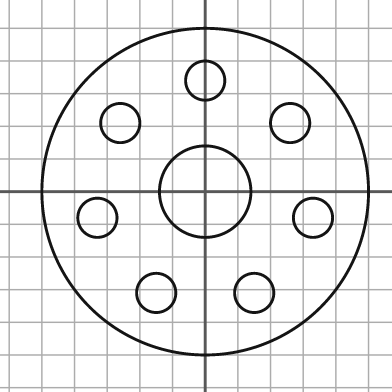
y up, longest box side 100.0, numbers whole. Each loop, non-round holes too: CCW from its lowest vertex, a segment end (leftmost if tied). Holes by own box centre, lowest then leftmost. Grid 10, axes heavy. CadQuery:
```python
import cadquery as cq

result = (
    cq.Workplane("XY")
    .moveTo(0.0, 0.0)
    .circle(50.0)
    .moveTo(-15.0, -31.0)
    .circle(6.0)
    .moveTo(15.0, -31.0)
    .circle(6.0)
    .moveTo(-33.0, -8.0)
    .circle(6.0)
    .moveTo(33.0, -8.0)
    .circle(6.0)
    .moveTo(0.0, 0.0)
    .circle(14.0)
    .moveTo(-26.0, 21.0)
    .circle(6.0)
    .moveTo(26.0, 21.0)
    .circle(6.0)
    .moveTo(0.0, 34.0)
    .circle(6.0)
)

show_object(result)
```